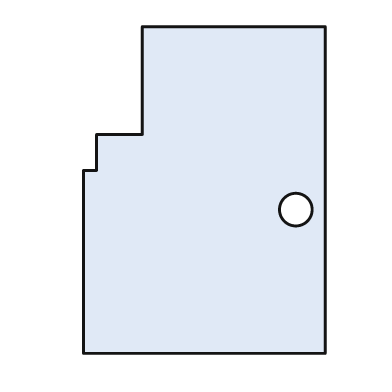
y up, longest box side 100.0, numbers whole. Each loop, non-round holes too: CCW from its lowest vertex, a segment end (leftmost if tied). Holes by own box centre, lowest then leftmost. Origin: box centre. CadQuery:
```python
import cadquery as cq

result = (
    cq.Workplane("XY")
    .moveTo(-37.0, -50.0)
    .lineTo(37.0, -50.0)
    .lineTo(37.0, 50.0)
    .lineTo(-19.0, 50.0)
    .lineTo(-19.0, 17.0)
    .lineTo(-33.0, 17.0)
    .lineTo(-33.0, 6.0)
    .lineTo(-37.0, 6.0)
    .close()
    .moveTo(28.0, -6.0)
    .circle(5.0)
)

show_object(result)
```